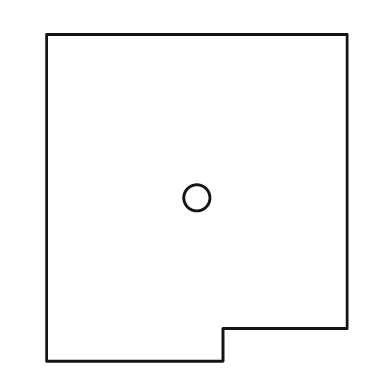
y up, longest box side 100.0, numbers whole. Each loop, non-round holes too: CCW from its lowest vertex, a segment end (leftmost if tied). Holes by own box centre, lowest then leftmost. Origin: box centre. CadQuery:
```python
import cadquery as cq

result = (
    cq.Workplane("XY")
    .moveTo(-46.0, -50.0)
    .lineTo(8.0, -50.0)
    .lineTo(8.0, -40.0)
    .lineTo(46.0, -40.0)
    .lineTo(46.0, 50.0)
    .lineTo(-46.0, 50.0)
    .close()
    .moveTo(0.0, 0.0)
    .circle(4.0)
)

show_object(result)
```